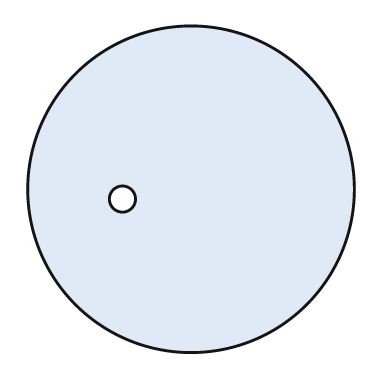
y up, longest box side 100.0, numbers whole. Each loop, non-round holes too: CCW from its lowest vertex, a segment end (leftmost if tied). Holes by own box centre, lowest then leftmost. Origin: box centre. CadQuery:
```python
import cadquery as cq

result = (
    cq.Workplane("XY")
    .moveTo(0.0, 0.0)
    .circle(50.0)
    .moveTo(-21.0, -3.0)
    .circle(4.0)
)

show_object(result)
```